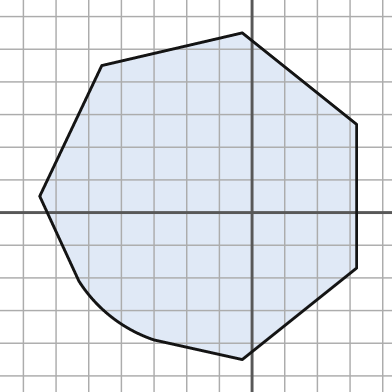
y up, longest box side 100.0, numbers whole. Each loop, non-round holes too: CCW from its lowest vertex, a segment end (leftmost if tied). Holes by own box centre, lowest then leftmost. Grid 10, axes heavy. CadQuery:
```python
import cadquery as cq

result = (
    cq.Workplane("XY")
    .moveTo(-3.0, -45.0)
    .lineTo(32.0, -17.0)
    .lineTo(32.0, 27.0)
    .lineTo(-3.0, 55.0)
    .lineTo(-46.0, 45.0)
    .lineTo(-65.0, 5.0)
    .lineTo(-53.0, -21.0)
    .threePointArc((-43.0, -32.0), (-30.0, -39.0))
    .close()
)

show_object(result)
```